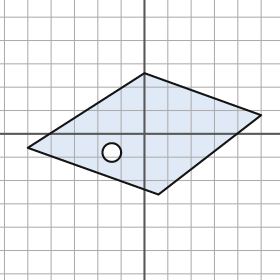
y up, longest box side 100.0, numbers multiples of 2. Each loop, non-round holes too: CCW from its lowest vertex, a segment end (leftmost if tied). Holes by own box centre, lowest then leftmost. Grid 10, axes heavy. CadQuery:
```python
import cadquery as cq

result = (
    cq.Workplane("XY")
    .moveTo(6.0, -26.0)
    .lineTo(50.0, 8.0)
    .lineTo(0.0, 26.0)
    .lineTo(-50.0, -6.0)
    .close()
    .moveTo(-14.0, -8.0)
    .circle(4.0)
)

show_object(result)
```